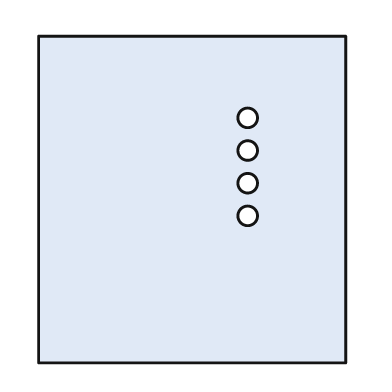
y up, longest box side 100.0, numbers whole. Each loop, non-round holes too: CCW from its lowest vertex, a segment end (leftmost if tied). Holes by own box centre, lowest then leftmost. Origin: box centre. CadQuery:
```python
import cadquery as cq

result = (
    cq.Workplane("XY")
    .moveTo(-47.0, -50.0)
    .lineTo(47.0, -50.0)
    .lineTo(47.0, 50.0)
    .lineTo(-47.0, 50.0)
    .close()
    .moveTo(17.0, -5.0)
    .circle(3.0)
    .moveTo(17.0, 5.0)
    .circle(3.0)
    .moveTo(17.0, 15.0)
    .circle(3.0)
    .moveTo(17.0, 25.0)
    .circle(3.0)
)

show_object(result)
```